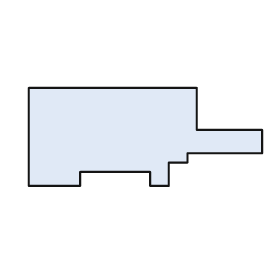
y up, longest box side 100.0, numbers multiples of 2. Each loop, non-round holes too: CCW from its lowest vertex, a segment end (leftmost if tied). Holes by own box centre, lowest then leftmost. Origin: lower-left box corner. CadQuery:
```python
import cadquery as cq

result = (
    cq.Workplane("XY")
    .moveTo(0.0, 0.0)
    .lineTo(22.0, 0.0)
    .lineTo(22.0, 6.0)
    .lineTo(52.0, 6.0)
    .lineTo(52.0, 0.0)
    .lineTo(60.0, 0.0)
    .lineTo(60.0, 10.0)
    .lineTo(68.0, 10.0)
    .lineTo(68.0, 14.0)
    .lineTo(100.0, 14.0)
    .lineTo(100.0, 24.0)
    .lineTo(72.0, 24.0)
    .lineTo(72.0, 42.0)
    .lineTo(0.0, 42.0)
    .close()
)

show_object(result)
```